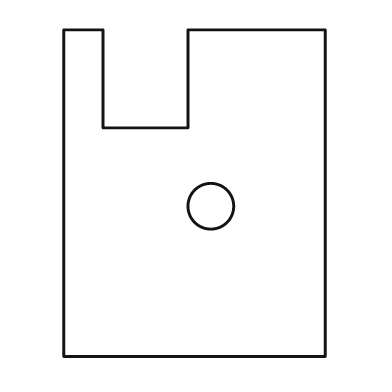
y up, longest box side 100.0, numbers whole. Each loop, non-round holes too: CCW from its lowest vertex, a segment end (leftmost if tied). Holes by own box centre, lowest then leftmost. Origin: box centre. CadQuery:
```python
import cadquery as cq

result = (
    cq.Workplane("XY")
    .moveTo(-40.0, -50.0)
    .lineTo(40.0, -50.0)
    .lineTo(40.0, 50.0)
    .lineTo(-2.0, 50.0)
    .lineTo(-2.0, 20.0)
    .lineTo(-28.0, 20.0)
    .lineTo(-28.0, 50.0)
    .lineTo(-40.0, 50.0)
    .close()
    .moveTo(5.0, -4.0)
    .circle(7.0)
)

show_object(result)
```